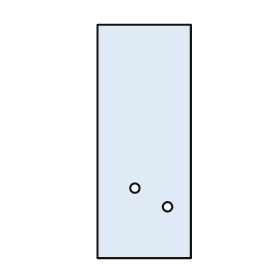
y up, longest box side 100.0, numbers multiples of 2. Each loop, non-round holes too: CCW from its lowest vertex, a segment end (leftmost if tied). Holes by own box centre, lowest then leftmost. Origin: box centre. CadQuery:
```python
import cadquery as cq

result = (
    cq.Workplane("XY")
    .moveTo(-20.0, -50.0)
    .lineTo(20.0, -50.0)
    .lineTo(20.0, 50.0)
    .lineTo(-20.0, 50.0)
    .close()
    .moveTo(10.0, -28.0)
    .circle(2.0)
    .moveTo(-4.0, -20.0)
    .circle(2.0)
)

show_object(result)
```